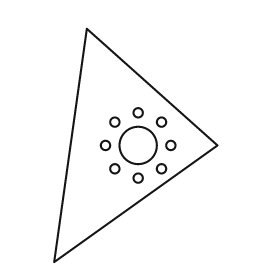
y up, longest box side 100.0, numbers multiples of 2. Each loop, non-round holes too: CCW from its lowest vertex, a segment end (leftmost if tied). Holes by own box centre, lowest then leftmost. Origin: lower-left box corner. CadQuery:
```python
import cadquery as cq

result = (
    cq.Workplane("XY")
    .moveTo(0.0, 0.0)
    .lineTo(70.0, 50.0)
    .lineTo(14.0, 100.0)
    .close()
    .moveTo(36.0, 36.0)
    .circle(2.0)
    .moveTo(26.0, 40.0)
    .circle(2.0)
    .moveTo(46.0, 40.0)
    .circle(2.0)
    .moveTo(22.0, 50.0)
    .circle(2.0)
    .moveTo(36.0, 50.0)
    .circle(8.0)
    .moveTo(50.0, 50.0)
    .circle(2.0)
    .moveTo(26.0, 60.0)
    .circle(2.0)
    .moveTo(46.0, 60.0)
    .circle(2.0)
    .moveTo(36.0, 64.0)
    .circle(2.0)
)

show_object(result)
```